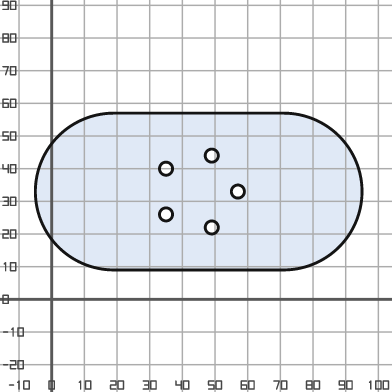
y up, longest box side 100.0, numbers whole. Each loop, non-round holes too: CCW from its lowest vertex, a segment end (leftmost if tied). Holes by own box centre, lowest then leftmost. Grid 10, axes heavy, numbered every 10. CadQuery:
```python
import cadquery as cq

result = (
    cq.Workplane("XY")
    .moveTo(19.0, 9.0)
    .lineTo(71.0, 9.0)
    .threePointArc((95.0, 33.0), (71.0, 57.0))
    .lineTo(19.0, 57.0)
    .threePointArc((-5.0, 33.0), (19.0, 9.0))
    .close()
    .moveTo(49.0, 22.0)
    .circle(2.0)
    .moveTo(35.0, 26.0)
    .circle(2.0)
    .moveTo(57.0, 33.0)
    .circle(2.0)
    .moveTo(35.0, 40.0)
    .circle(2.0)
    .moveTo(49.0, 44.0)
    .circle(2.0)
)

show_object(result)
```